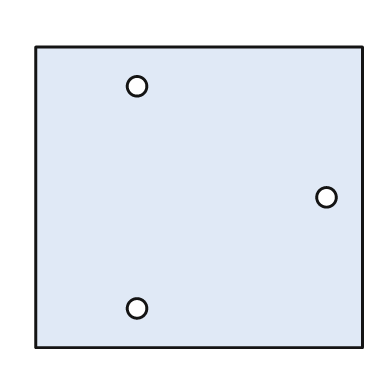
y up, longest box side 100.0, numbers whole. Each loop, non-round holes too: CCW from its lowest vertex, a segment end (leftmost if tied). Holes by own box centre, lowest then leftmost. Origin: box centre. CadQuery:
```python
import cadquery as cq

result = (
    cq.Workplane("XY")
    .moveTo(-50.0, -46.0)
    .lineTo(50.0, -46.0)
    .lineTo(50.0, 46.0)
    .lineTo(-50.0, 46.0)
    .close()
    .moveTo(-19.0, -34.0)
    .circle(3.0)
    .moveTo(39.0, 0.0)
    .circle(3.0)
    .moveTo(-19.0, 34.0)
    .circle(3.0)
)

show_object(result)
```